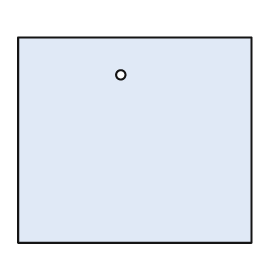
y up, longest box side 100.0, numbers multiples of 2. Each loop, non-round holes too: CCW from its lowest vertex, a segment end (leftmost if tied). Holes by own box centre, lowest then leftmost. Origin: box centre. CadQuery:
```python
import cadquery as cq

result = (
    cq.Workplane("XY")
    .moveTo(-50.0, -44.0)
    .lineTo(50.0, -44.0)
    .lineTo(50.0, 44.0)
    .lineTo(-50.0, 44.0)
    .close()
    .moveTo(-6.0, 28.0)
    .circle(2.0)
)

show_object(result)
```